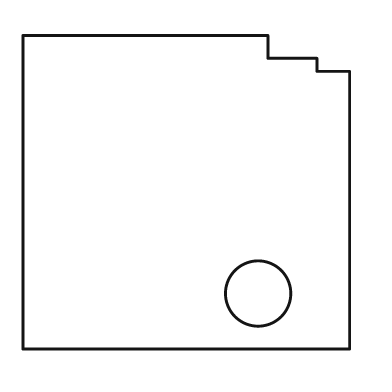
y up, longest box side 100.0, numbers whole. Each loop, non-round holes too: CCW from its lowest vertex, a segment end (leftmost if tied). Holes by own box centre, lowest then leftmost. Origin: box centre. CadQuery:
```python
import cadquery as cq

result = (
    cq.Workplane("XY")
    .moveTo(-50.0, -48.0)
    .lineTo(50.0, -48.0)
    .lineTo(50.0, 37.0)
    .lineTo(40.0, 37.0)
    .lineTo(40.0, 41.0)
    .lineTo(25.0, 41.0)
    .lineTo(25.0, 48.0)
    .lineTo(-50.0, 48.0)
    .close()
    .moveTo(22.0, -31.0)
    .circle(10.0)
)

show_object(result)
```